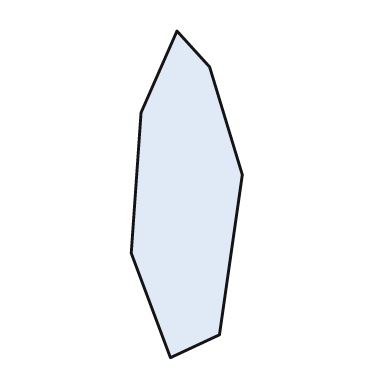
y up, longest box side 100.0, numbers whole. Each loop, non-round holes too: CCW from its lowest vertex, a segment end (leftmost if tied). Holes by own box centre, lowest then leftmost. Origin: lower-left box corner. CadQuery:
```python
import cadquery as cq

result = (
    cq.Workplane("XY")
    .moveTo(12.0, 0.0)
    .lineTo(27.0, 7.0)
    .lineTo(34.0, 56.0)
    .lineTo(24.0, 89.0)
    .lineTo(14.0, 100.0)
    .lineTo(3.0, 75.0)
    .lineTo(0.0, 32.0)
    .close()
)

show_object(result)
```